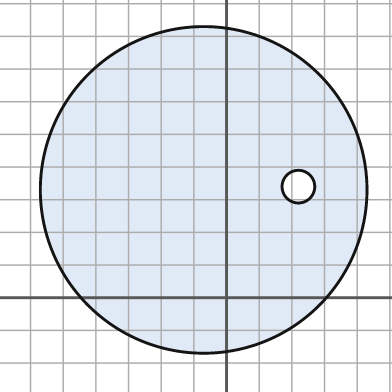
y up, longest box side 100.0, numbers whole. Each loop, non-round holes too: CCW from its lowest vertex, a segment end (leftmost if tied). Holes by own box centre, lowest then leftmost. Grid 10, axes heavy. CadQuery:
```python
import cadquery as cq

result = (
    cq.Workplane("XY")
    .moveTo(-7.0, 33.0)
    .circle(50.0)
    .moveTo(22.0, 34.0)
    .circle(5.0)
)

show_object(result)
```